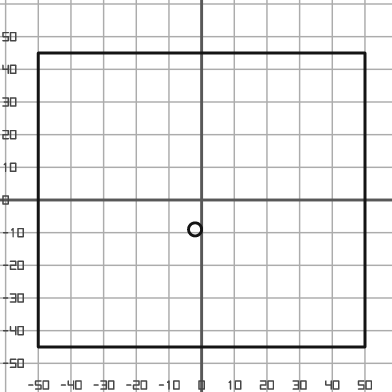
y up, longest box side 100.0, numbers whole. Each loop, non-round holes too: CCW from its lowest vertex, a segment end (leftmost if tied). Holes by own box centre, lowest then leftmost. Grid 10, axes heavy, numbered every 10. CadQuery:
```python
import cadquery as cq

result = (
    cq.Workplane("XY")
    .moveTo(-50.0, -45.0)
    .lineTo(50.0, -45.0)
    .lineTo(50.0, 45.0)
    .lineTo(-50.0, 45.0)
    .close()
    .moveTo(-2.0, -9.0)
    .circle(2.0)
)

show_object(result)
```